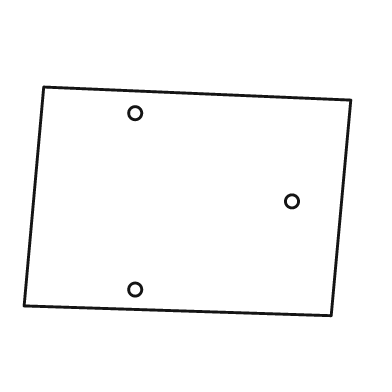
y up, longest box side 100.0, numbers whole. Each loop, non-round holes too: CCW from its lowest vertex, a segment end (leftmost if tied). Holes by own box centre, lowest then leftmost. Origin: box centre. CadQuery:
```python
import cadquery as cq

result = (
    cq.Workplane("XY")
    .moveTo(44.0, -35.0)
    .lineTo(50.0, 31.0)
    .lineTo(-44.0, 35.0)
    .lineTo(-50.0, -32.0)
    .close()
    .moveTo(-16.0, -27.0)
    .circle(2.0)
    .moveTo(32.0, 0.0)
    .circle(2.0)
    .moveTo(-16.0, 27.0)
    .circle(2.0)
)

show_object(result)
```